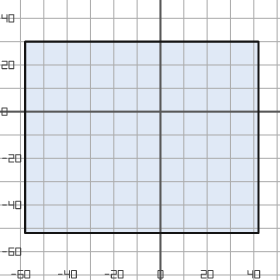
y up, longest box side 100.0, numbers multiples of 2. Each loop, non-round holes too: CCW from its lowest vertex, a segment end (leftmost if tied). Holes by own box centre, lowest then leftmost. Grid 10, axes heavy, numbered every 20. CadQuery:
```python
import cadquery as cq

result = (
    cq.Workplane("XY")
    .moveTo(-58.0, -52.0)
    .lineTo(42.0, -52.0)
    .lineTo(42.0, 30.0)
    .lineTo(-58.0, 30.0)
    .close()
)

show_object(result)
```